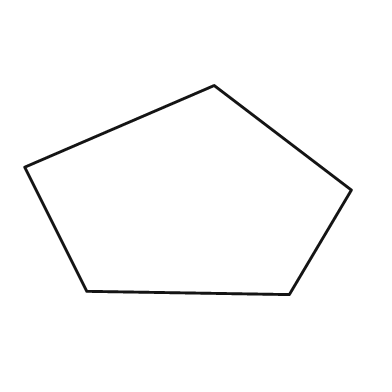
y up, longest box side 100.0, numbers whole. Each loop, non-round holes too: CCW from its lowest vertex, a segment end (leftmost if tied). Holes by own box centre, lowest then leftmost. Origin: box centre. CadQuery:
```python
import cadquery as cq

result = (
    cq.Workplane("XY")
    .moveTo(31.0, -32.0)
    .lineTo(50.0, 0.0)
    .lineTo(8.0, 32.0)
    .lineTo(-50.0, 7.0)
    .lineTo(-31.0, -31.0)
    .close()
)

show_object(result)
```